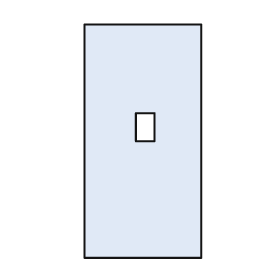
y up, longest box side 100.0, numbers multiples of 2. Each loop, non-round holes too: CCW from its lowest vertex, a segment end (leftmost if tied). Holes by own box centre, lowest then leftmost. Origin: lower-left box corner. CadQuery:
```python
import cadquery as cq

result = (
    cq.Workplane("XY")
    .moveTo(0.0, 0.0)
    .lineTo(50.0, 0.0)
    .lineTo(50.0, 100.0)
    .lineTo(0.0, 100.0)
    .close()
    .moveTo(22.0, 50.0)
    .lineTo(30.0, 50.0)
    .lineTo(30.0, 62.0)
    .lineTo(22.0, 62.0)
    .close()
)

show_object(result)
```